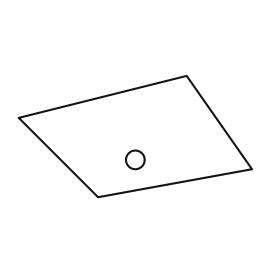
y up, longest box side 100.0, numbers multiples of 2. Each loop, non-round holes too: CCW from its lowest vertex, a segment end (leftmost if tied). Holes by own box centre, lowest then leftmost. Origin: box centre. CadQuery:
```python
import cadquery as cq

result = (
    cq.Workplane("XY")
    .moveTo(-16.0, -26.0)
    .lineTo(50.0, -14.0)
    .lineTo(22.0, 26.0)
    .lineTo(-50.0, 8.0)
    .close()
    .moveTo(0.0, -10.0)
    .circle(4.0)
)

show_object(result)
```